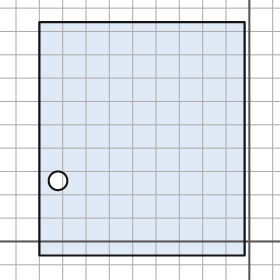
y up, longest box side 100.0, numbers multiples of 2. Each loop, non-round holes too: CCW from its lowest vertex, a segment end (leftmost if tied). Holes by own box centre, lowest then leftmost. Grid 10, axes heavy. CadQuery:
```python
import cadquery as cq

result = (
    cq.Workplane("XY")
    .moveTo(-90.0, -6.0)
    .lineTo(-2.0, -6.0)
    .lineTo(-2.0, 94.0)
    .lineTo(-90.0, 94.0)
    .close()
    .moveTo(-82.0, 26.0)
    .circle(4.0)
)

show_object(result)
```